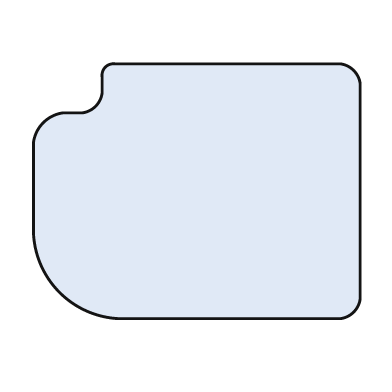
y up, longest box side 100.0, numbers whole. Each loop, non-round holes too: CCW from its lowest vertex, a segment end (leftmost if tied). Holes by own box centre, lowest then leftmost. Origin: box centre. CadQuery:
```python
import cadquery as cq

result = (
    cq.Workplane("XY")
    .moveTo(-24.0, -39.0)
    .lineTo(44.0, -39.0)
    .threePointArc((48.0, -37.0), (50.0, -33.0))
    .lineTo(50.0, 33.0)
    .threePointArc((48.0, 37.0), (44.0, 39.0))
    .lineTo(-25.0, 39.0)
    .threePointArc((-28.0, 38.0), (-29.0, 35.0))
    .lineTo(-29.0, 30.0)
    .threePointArc((-31.0, 26.0), (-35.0, 24.0))
    .lineTo(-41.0, 24.0)
    .threePointArc((-47.0, 21.0), (-50.0, 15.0))
    .lineTo(-50.0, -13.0)
    .threePointArc((-42.0, -31.0), (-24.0, -39.0))
    .close()
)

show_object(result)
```